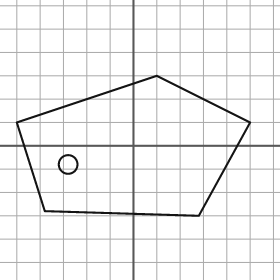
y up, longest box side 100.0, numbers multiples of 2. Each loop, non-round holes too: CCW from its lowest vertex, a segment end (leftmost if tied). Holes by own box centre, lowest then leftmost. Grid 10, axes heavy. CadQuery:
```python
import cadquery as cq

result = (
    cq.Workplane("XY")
    .moveTo(28.0, -30.0)
    .lineTo(50.0, 10.0)
    .lineTo(10.0, 30.0)
    .lineTo(-50.0, 10.0)
    .lineTo(-38.0, -28.0)
    .close()
    .moveTo(-28.0, -8.0)
    .circle(4.0)
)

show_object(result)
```